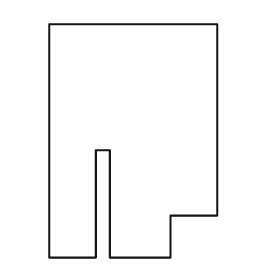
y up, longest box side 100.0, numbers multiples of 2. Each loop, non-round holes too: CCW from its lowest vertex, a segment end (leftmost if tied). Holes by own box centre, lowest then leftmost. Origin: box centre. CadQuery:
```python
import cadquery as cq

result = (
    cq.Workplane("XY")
    .moveTo(-36.0, -50.0)
    .lineTo(-16.0, -50.0)
    .lineTo(-16.0, -4.0)
    .lineTo(-10.0, -4.0)
    .lineTo(-10.0, -50.0)
    .lineTo(16.0, -50.0)
    .lineTo(16.0, -32.0)
    .lineTo(36.0, -32.0)
    .lineTo(36.0, 50.0)
    .lineTo(-36.0, 50.0)
    .close()
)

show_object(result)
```